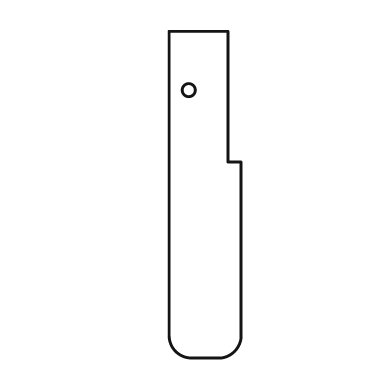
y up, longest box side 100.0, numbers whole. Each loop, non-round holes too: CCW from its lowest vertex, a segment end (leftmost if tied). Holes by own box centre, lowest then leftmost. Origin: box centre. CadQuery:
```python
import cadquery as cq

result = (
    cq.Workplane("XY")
    .moveTo(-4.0, -50.0)
    .lineTo(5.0, -50.0)
    .threePointArc((9.0, -48.0), (11.0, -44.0))
    .lineTo(11.0, 10.0)
    .lineTo(7.0, 10.0)
    .lineTo(7.0, 50.0)
    .lineTo(-11.0, 50.0)
    .lineTo(-11.0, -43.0)
    .threePointArc((-9.0, -48.0), (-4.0, -50.0))
    .close()
    .moveTo(-5.0, 32.0)
    .circle(2.0)
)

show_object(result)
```